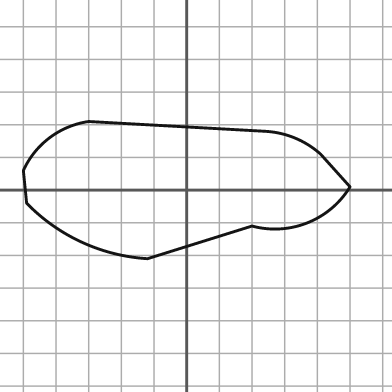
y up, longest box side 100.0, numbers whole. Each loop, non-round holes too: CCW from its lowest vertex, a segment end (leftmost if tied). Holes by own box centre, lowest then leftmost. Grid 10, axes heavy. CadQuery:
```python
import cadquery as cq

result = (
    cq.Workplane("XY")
    .moveTo(-12.0, -21.0)
    .lineTo(20.0, -11.0)
    .threePointArc((37.0, -10.0), (50.0, 1.0))
    .lineTo(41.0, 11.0)
    .threePointArc((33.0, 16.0), (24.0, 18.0))
    .lineTo(-30.0, 21.0)
    .threePointArc((-42.0, 16.0), (-50.0, 6.0))
    .lineTo(-49.0, -4.0)
    .threePointArc((-32.0, -16.0), (-12.0, -21.0))
    .close()
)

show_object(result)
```